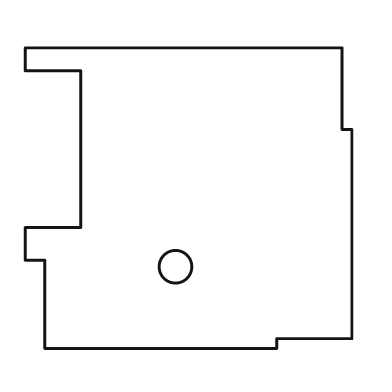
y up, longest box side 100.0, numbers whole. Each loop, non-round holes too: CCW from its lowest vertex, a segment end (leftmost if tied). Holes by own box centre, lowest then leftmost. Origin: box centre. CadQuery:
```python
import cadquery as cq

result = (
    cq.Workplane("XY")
    .moveTo(-44.0, -46.0)
    .lineTo(27.0, -46.0)
    .lineTo(27.0, -43.0)
    .lineTo(50.0, -43.0)
    .lineTo(50.0, 21.0)
    .lineTo(47.0, 21.0)
    .lineTo(47.0, 46.0)
    .lineTo(-50.0, 46.0)
    .lineTo(-50.0, 39.0)
    .lineTo(-33.0, 39.0)
    .lineTo(-33.0, -9.0)
    .lineTo(-50.0, -9.0)
    .lineTo(-50.0, -19.0)
    .lineTo(-44.0, -19.0)
    .close()
    .moveTo(-4.0, -21.0)
    .circle(5.0)
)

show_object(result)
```